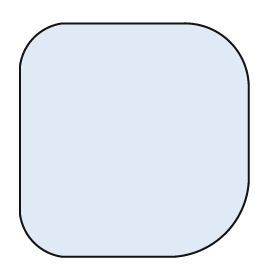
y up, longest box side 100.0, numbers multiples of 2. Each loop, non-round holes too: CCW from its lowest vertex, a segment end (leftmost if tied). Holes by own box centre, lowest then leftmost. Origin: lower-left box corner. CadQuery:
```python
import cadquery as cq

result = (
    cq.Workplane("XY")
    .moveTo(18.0, 0.0)
    .lineTo(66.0, 0.0)
    .threePointArc((88.0, 10.0), (98.0, 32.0))
    .lineTo(98.0, 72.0)
    .threePointArc((90.0, 92.0), (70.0, 100.0))
    .lineTo(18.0, 100.0)
    .threePointArc((6.0, 94.0), (0.0, 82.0))
    .lineTo(0.0, 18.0)
    .threePointArc((6.0, 6.0), (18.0, 0.0))
    .close()
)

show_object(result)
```